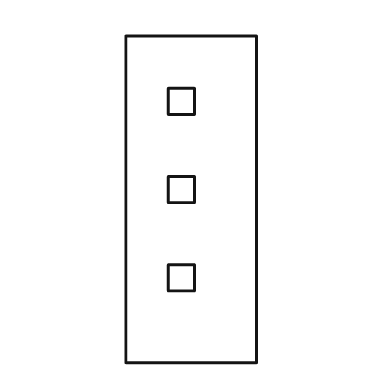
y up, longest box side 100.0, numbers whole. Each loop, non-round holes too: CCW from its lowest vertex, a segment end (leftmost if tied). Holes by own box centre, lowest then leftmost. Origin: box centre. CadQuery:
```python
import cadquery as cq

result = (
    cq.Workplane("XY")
    .moveTo(-20.0, -50.0)
    .lineTo(20.0, -50.0)
    .lineTo(20.0, 50.0)
    .lineTo(-20.0, 50.0)
    .close()
    .moveTo(-7.0, -28.0)
    .lineTo(1.0, -28.0)
    .lineTo(1.0, -20.0)
    .lineTo(-7.0, -20.0)
    .close()
    .moveTo(-7.0, -1.0)
    .lineTo(1.0, -1.0)
    .lineTo(1.0, 7.0)
    .lineTo(-7.0, 7.0)
    .close()
    .moveTo(-7.0, 26.0)
    .lineTo(1.0, 26.0)
    .lineTo(1.0, 34.0)
    .lineTo(-7.0, 34.0)
    .close()
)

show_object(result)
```